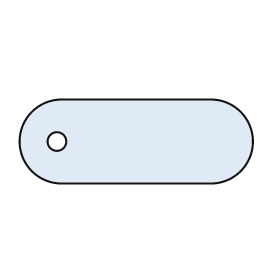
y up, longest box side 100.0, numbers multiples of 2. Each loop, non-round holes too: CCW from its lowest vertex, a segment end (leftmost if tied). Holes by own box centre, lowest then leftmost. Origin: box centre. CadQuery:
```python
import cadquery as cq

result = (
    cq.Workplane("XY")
    .moveTo(-32.0, -18.0)
    .lineTo(32.0, -18.0)
    .threePointArc((50.0, 0.0), (32.0, 18.0))
    .lineTo(-32.0, 18.0)
    .threePointArc((-50.0, 0.0), (-32.0, -18.0))
    .close()
    .moveTo(-34.0, 0.0)
    .circle(4.0)
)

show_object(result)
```